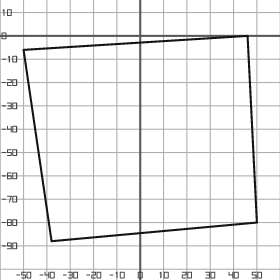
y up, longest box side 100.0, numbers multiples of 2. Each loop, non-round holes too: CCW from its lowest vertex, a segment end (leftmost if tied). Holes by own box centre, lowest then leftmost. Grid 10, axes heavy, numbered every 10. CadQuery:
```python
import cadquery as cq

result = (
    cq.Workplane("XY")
    .moveTo(-38.0, -88.0)
    .lineTo(50.0, -80.0)
    .lineTo(46.0, 0.0)
    .lineTo(-50.0, -6.0)
    .close()
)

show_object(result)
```